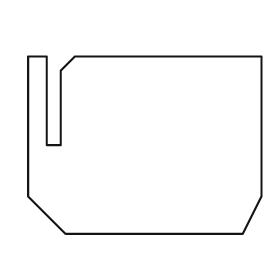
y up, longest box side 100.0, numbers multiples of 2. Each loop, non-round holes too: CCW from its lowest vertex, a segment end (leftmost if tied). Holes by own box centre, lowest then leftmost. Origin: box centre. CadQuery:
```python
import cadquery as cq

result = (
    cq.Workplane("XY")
    .moveTo(-34.0, -38.0)
    .lineTo(42.0, -38.0)
    .lineTo(50.0, -22.0)
    .lineTo(50.0, 38.0)
    .lineTo(-30.0, 38.0)
    .lineTo(-36.0, 32.0)
    .lineTo(-36.0, 0.0)
    .lineTo(-42.0, 0.0)
    .lineTo(-42.0, 38.0)
    .lineTo(-50.0, 38.0)
    .lineTo(-50.0, -22.0)
    .close()
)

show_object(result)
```